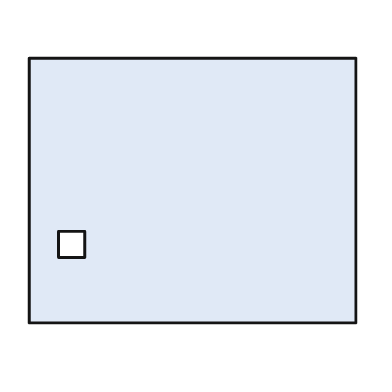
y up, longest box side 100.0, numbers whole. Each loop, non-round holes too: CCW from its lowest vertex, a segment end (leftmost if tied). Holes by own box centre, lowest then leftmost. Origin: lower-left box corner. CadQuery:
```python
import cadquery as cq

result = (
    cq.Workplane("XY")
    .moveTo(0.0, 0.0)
    .lineTo(100.0, 0.0)
    .lineTo(100.0, 81.0)
    .lineTo(0.0, 81.0)
    .close()
    .moveTo(9.0, 20.0)
    .lineTo(17.0, 20.0)
    .lineTo(17.0, 28.0)
    .lineTo(9.0, 28.0)
    .close()
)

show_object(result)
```